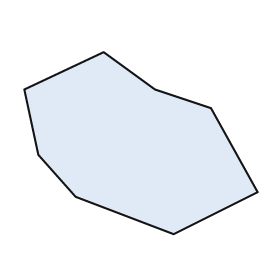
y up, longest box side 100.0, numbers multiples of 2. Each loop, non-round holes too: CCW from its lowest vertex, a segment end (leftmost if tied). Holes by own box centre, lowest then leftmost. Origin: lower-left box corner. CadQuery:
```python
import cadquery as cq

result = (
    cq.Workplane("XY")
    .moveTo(64.0, 0.0)
    .lineTo(100.0, 18.0)
    .lineTo(80.0, 54.0)
    .lineTo(56.0, 62.0)
    .lineTo(34.0, 78.0)
    .lineTo(0.0, 62.0)
    .lineTo(6.0, 34.0)
    .lineTo(22.0, 16.0)
    .close()
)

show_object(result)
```